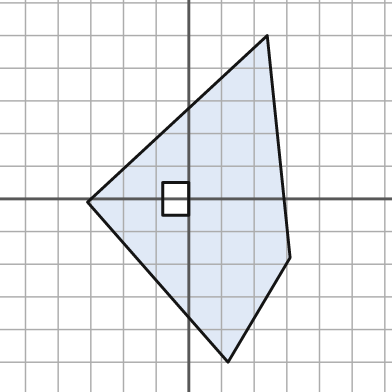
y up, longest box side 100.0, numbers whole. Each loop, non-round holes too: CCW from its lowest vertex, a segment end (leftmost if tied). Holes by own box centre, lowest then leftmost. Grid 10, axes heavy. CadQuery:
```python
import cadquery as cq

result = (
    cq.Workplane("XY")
    .moveTo(12.0, -50.0)
    .lineTo(31.0, -18.0)
    .lineTo(24.0, 50.0)
    .lineTo(-31.0, -1.0)
    .close()
    .moveTo(-8.0, -5.0)
    .lineTo(0.0, -5.0)
    .lineTo(0.0, 5.0)
    .lineTo(-8.0, 5.0)
    .close()
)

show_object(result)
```